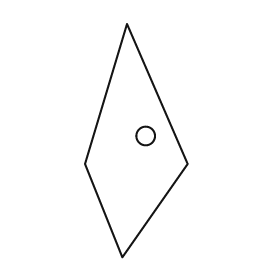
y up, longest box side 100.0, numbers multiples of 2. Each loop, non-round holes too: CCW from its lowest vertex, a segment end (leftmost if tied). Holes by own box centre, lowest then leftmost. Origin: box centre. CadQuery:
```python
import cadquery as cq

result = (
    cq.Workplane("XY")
    .moveTo(-6.0, -50.0)
    .lineTo(22.0, -10.0)
    .lineTo(-4.0, 50.0)
    .lineTo(-22.0, -10.0)
    .close()
    .moveTo(4.0, 2.0)
    .circle(4.0)
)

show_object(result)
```